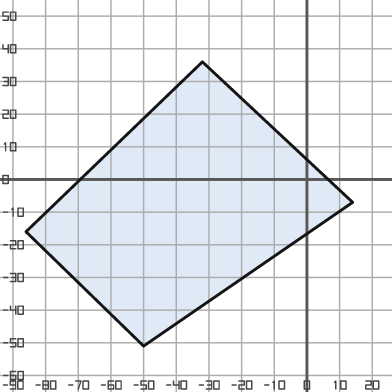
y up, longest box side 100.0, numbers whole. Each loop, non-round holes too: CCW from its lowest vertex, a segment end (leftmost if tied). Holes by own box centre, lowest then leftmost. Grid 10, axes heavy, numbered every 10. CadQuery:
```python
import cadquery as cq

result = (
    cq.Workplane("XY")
    .moveTo(-50.0, -51.0)
    .lineTo(14.0, -7.0)
    .lineTo(-32.0, 36.0)
    .lineTo(-86.0, -16.0)
    .close()
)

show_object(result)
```